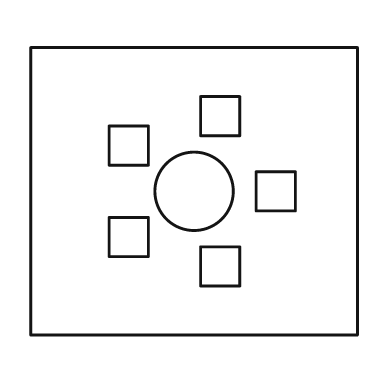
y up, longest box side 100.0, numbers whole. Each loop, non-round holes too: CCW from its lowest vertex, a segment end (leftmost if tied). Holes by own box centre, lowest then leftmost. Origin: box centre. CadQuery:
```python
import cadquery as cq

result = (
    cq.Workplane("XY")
    .moveTo(-50.0, -44.0)
    .lineTo(50.0, -44.0)
    .lineTo(50.0, 44.0)
    .lineTo(-50.0, 44.0)
    .close()
    .moveTo(2.0, -29.0)
    .lineTo(14.0, -29.0)
    .lineTo(14.0, -17.0)
    .lineTo(2.0, -17.0)
    .close()
    .moveTo(-26.0, -20.0)
    .lineTo(-14.0, -20.0)
    .lineTo(-14.0, -8.0)
    .lineTo(-26.0, -8.0)
    .close()
    .moveTo(0.0, 0.0)
    .circle(12.0)
    .moveTo(19.0, -6.0)
    .lineTo(31.0, -6.0)
    .lineTo(31.0, 6.0)
    .lineTo(19.0, 6.0)
    .close()
    .moveTo(-26.0, 8.0)
    .lineTo(-14.0, 8.0)
    .lineTo(-14.0, 20.0)
    .lineTo(-26.0, 20.0)
    .close()
    .moveTo(2.0, 17.0)
    .lineTo(14.0, 17.0)
    .lineTo(14.0, 29.0)
    .lineTo(2.0, 29.0)
    .close()
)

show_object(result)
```